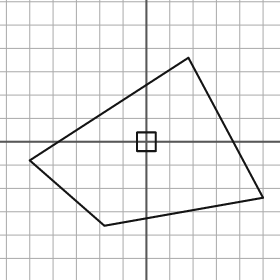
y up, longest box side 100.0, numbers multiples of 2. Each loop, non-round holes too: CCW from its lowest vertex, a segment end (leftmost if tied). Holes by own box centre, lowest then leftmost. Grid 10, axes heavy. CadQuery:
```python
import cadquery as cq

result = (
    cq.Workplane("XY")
    .moveTo(-18.0, -36.0)
    .lineTo(50.0, -24.0)
    .lineTo(18.0, 36.0)
    .lineTo(-50.0, -8.0)
    .close()
    .moveTo(-4.0, -4.0)
    .lineTo(4.0, -4.0)
    .lineTo(4.0, 4.0)
    .lineTo(-4.0, 4.0)
    .close()
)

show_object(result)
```